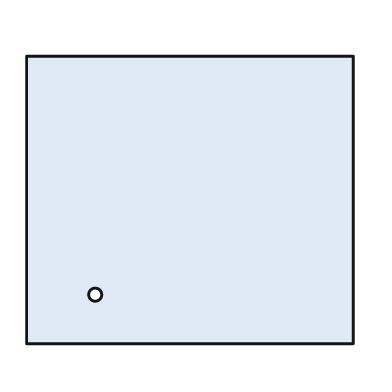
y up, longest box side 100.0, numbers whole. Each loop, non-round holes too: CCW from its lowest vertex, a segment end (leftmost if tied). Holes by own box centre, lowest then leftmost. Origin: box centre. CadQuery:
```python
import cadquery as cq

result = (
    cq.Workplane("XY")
    .moveTo(-50.0, -44.0)
    .lineTo(50.0, -44.0)
    .lineTo(50.0, 44.0)
    .lineTo(-50.0, 44.0)
    .close()
    .moveTo(-29.0, -29.0)
    .circle(2.0)
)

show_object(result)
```